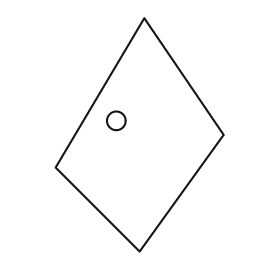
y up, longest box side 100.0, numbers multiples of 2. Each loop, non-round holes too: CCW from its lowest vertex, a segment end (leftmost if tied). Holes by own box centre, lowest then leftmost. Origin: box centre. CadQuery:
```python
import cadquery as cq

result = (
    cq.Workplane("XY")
    .moveTo(0.0, -50.0)
    .lineTo(36.0, 0.0)
    .lineTo(2.0, 50.0)
    .lineTo(-36.0, -14.0)
    .close()
    .moveTo(-10.0, 6.0)
    .circle(4.0)
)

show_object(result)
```